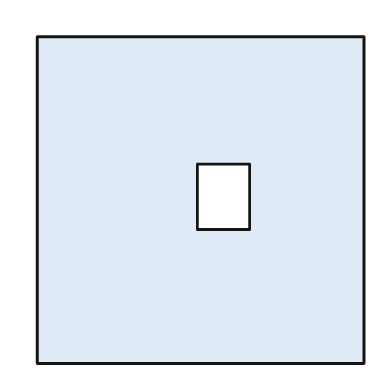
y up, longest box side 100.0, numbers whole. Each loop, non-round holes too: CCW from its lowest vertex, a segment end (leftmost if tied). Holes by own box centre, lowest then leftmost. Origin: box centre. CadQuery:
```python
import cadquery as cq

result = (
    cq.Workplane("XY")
    .moveTo(-50.0, -50.0)
    .lineTo(50.0, -50.0)
    .lineTo(50.0, 50.0)
    .lineTo(-50.0, 50.0)
    .close()
    .moveTo(-1.0, -9.0)
    .lineTo(15.0, -9.0)
    .lineTo(15.0, 11.0)
    .lineTo(-1.0, 11.0)
    .close()
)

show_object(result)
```